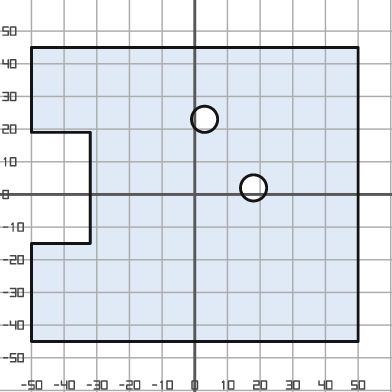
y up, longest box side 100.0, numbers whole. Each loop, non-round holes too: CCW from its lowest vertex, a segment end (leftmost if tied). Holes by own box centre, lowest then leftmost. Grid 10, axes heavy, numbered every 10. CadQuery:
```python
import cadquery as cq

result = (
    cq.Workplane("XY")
    .moveTo(-50.0, -45.0)
    .lineTo(50.0, -45.0)
    .lineTo(50.0, 45.0)
    .lineTo(-50.0, 45.0)
    .lineTo(-50.0, 19.0)
    .lineTo(-32.0, 19.0)
    .lineTo(-32.0, -15.0)
    .lineTo(-50.0, -15.0)
    .close()
    .moveTo(18.0, 2.0)
    .circle(4.0)
    .moveTo(3.0, 23.0)
    .circle(4.0)
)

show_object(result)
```